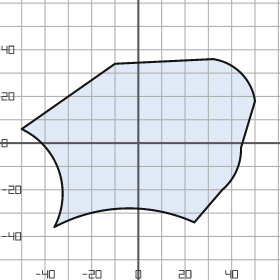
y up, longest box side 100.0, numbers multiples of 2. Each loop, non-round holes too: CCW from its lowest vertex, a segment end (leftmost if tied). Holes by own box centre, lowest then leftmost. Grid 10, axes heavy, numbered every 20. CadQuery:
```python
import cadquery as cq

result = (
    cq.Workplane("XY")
    .moveTo(-36.0, -36.0)
    .threePointArc((-6.0, -28.0), (24.0, -34.0))
    .lineTo(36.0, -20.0)
    .threePointArc((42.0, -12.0), (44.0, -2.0))
    .lineTo(50.0, 18.0)
    .threePointArc((44.0, 30.0), (32.0, 36.0))
    .lineTo(-10.0, 34.0)
    .lineTo(-50.0, 6.0)
    .threePointArc((-34.0, -12.0), (-36.0, -36.0))
    .close()
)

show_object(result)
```